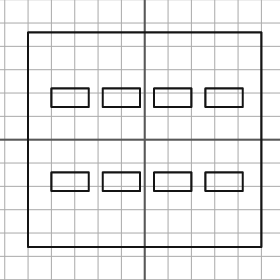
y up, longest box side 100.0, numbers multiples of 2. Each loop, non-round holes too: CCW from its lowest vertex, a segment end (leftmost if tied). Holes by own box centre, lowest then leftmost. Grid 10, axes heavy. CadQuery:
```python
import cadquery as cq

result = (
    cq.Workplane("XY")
    .moveTo(-50.0, -46.0)
    .lineTo(50.0, -46.0)
    .lineTo(50.0, 46.0)
    .lineTo(-50.0, 46.0)
    .close()
    .moveTo(-40.0, -22.0)
    .lineTo(-24.0, -22.0)
    .lineTo(-24.0, -14.0)
    .lineTo(-40.0, -14.0)
    .close()
    .moveTo(-18.0, -22.0)
    .lineTo(-2.0, -22.0)
    .lineTo(-2.0, -14.0)
    .lineTo(-18.0, -14.0)
    .close()
    .moveTo(4.0, -22.0)
    .lineTo(20.0, -22.0)
    .lineTo(20.0, -14.0)
    .lineTo(4.0, -14.0)
    .close()
    .moveTo(26.0, -22.0)
    .lineTo(42.0, -22.0)
    .lineTo(42.0, -14.0)
    .lineTo(26.0, -14.0)
    .close()
    .moveTo(-40.0, 14.0)
    .lineTo(-24.0, 14.0)
    .lineTo(-24.0, 22.0)
    .lineTo(-40.0, 22.0)
    .close()
    .moveTo(-18.0, 14.0)
    .lineTo(-2.0, 14.0)
    .lineTo(-2.0, 22.0)
    .lineTo(-18.0, 22.0)
    .close()
    .moveTo(4.0, 14.0)
    .lineTo(20.0, 14.0)
    .lineTo(20.0, 22.0)
    .lineTo(4.0, 22.0)
    .close()
    .moveTo(26.0, 14.0)
    .lineTo(42.0, 14.0)
    .lineTo(42.0, 22.0)
    .lineTo(26.0, 22.0)
    .close()
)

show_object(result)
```